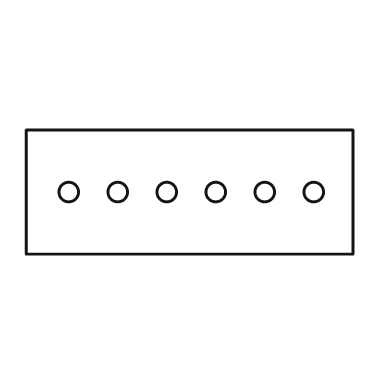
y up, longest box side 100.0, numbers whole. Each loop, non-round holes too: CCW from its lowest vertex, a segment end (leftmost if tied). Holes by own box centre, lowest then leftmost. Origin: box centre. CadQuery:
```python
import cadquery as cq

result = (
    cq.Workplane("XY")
    .moveTo(-50.0, -19.0)
    .lineTo(50.0, -19.0)
    .lineTo(50.0, 19.0)
    .lineTo(-50.0, 19.0)
    .close()
    .moveTo(-37.0, 0.0)
    .circle(3.0)
    .moveTo(-22.0, 0.0)
    .circle(3.0)
    .moveTo(-7.0, 0.0)
    .circle(3.0)
    .moveTo(8.0, 0.0)
    .circle(3.0)
    .moveTo(23.0, 0.0)
    .circle(3.0)
    .moveTo(38.0, 0.0)
    .circle(3.0)
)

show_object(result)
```